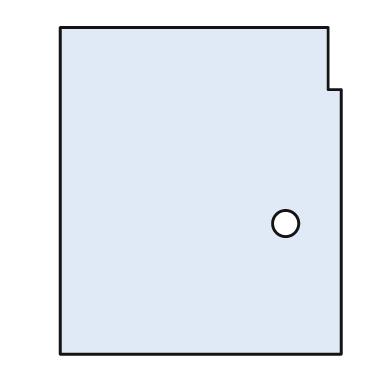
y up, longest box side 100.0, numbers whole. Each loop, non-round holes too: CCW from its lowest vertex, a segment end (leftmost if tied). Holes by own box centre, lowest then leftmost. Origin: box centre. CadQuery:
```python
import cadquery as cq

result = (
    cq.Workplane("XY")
    .moveTo(-43.0, -50.0)
    .lineTo(43.0, -50.0)
    .lineTo(43.0, 31.0)
    .lineTo(39.0, 31.0)
    .lineTo(39.0, 50.0)
    .lineTo(-43.0, 50.0)
    .close()
    .moveTo(26.0, -10.0)
    .circle(4.0)
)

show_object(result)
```